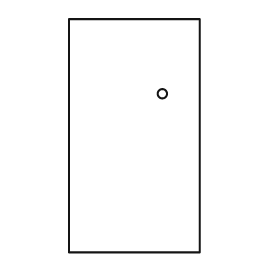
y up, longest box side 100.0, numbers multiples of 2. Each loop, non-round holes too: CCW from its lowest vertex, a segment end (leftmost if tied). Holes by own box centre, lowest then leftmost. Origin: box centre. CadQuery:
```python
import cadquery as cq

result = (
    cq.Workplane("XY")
    .moveTo(-28.0, -50.0)
    .lineTo(28.0, -50.0)
    .lineTo(28.0, 50.0)
    .lineTo(-28.0, 50.0)
    .close()
    .moveTo(12.0, 18.0)
    .circle(2.0)
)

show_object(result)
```